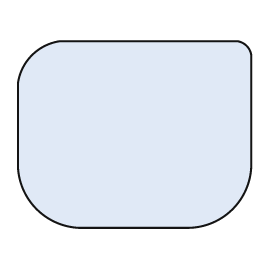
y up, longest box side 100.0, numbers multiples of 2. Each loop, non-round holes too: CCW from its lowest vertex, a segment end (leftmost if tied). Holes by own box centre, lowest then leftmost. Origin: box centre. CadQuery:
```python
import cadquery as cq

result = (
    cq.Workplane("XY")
    .moveTo(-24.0, -40.0)
    .lineTo(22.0, -40.0)
    .threePointArc((42.0, -32.0), (50.0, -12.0))
    .lineTo(50.0, 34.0)
    .threePointArc((48.0, 38.0), (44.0, 40.0))
    .lineTo(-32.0, 40.0)
    .threePointArc((-44.0, 34.0), (-50.0, 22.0))
    .lineTo(-50.0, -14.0)
    .threePointArc((-42.0, -32.0), (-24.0, -40.0))
    .close()
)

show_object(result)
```